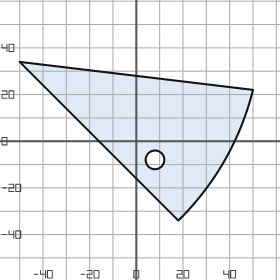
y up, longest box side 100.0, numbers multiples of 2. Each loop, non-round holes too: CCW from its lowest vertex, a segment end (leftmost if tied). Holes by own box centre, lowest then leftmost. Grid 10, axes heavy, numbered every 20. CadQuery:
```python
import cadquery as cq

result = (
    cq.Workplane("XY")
    .moveTo(18.0, -34.0)
    .threePointArc((38.0, -8.0), (50.0, 22.0))
    .lineTo(-50.0, 34.0)
    .close()
    .moveTo(8.0, -8.0)
    .circle(4.0)
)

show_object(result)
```